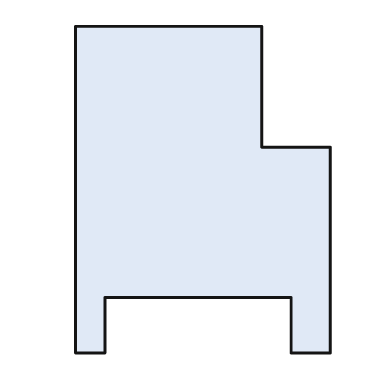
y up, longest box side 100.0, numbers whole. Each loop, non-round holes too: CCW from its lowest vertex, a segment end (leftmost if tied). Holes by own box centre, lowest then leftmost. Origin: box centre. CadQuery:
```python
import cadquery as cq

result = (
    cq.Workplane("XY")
    .moveTo(-39.0, -50.0)
    .lineTo(-30.0, -50.0)
    .lineTo(-30.0, -33.0)
    .lineTo(27.0, -33.0)
    .lineTo(27.0, -50.0)
    .lineTo(39.0, -50.0)
    .lineTo(39.0, 13.0)
    .lineTo(18.0, 13.0)
    .lineTo(18.0, 50.0)
    .lineTo(-39.0, 50.0)
    .close()
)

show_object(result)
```